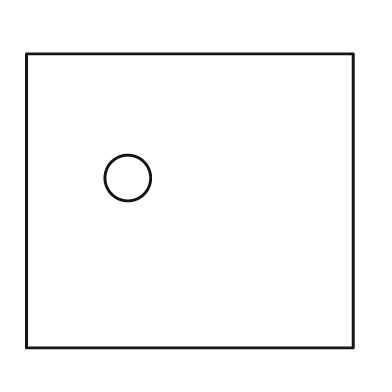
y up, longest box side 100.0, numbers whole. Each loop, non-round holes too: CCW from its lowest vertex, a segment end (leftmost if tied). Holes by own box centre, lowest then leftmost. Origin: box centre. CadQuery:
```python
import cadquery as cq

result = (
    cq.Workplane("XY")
    .moveTo(-50.0, -45.0)
    .lineTo(50.0, -45.0)
    .lineTo(50.0, 45.0)
    .lineTo(-50.0, 45.0)
    .close()
    .moveTo(-19.0, 7.0)
    .circle(7.0)
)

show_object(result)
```